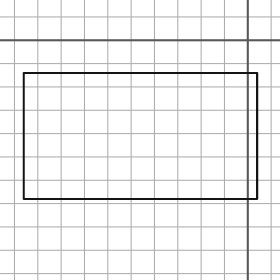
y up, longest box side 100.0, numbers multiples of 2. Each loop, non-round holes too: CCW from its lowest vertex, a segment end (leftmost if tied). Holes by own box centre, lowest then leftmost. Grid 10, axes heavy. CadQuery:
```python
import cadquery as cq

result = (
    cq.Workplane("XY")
    .moveTo(-96.0, -68.0)
    .lineTo(4.0, -68.0)
    .lineTo(4.0, -14.0)
    .lineTo(-96.0, -14.0)
    .close()
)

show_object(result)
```